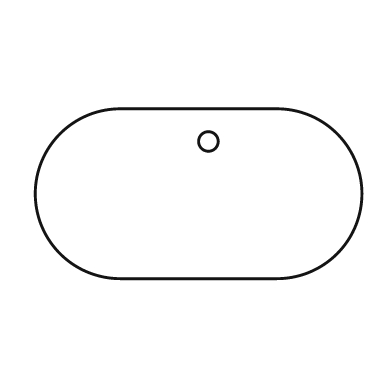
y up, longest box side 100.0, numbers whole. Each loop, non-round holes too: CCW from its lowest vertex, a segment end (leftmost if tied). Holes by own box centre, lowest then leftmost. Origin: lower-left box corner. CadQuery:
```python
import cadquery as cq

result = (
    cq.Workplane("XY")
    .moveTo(26.0, 0.0)
    .lineTo(74.0, 0.0)
    .threePointArc((100.0, 26.0), (74.0, 52.0))
    .lineTo(26.0, 52.0)
    .threePointArc((0.0, 26.0), (26.0, 0.0))
    .close()
    .moveTo(53.0, 42.0)
    .circle(3.0)
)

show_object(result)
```